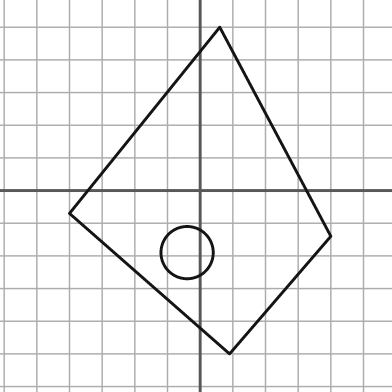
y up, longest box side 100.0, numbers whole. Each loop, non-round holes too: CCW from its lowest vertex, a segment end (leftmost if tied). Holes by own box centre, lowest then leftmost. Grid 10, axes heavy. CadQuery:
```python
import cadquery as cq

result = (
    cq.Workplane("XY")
    .moveTo(9.0, -50.0)
    .lineTo(40.0, -14.0)
    .lineTo(6.0, 50.0)
    .lineTo(-40.0, -7.0)
    .close()
    .moveTo(-4.0, -19.0)
    .circle(8.0)
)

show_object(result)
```